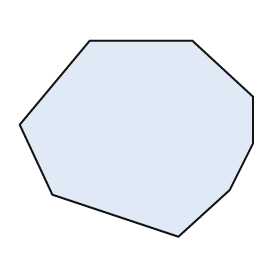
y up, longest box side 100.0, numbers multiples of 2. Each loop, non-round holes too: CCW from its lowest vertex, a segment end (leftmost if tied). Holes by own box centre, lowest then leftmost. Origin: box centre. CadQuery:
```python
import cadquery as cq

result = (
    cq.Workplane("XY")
    .moveTo(18.0, -42.0)
    .lineTo(40.0, -22.0)
    .lineTo(50.0, -2.0)
    .lineTo(50.0, 18.0)
    .lineTo(24.0, 42.0)
    .lineTo(-20.0, 42.0)
    .lineTo(-50.0, 6.0)
    .lineTo(-36.0, -24.0)
    .close()
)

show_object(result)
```